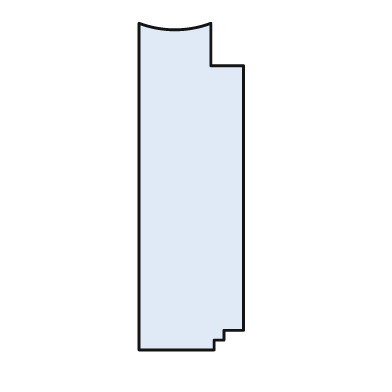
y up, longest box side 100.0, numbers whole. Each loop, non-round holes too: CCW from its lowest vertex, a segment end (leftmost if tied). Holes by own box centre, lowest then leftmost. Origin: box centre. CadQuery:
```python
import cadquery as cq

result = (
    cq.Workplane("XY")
    .moveTo(-16.0, -50.0)
    .lineTo(7.0, -50.0)
    .lineTo(7.0, -47.0)
    .lineTo(10.0, -47.0)
    .lineTo(10.0, -44.0)
    .lineTo(16.0, -44.0)
    .lineTo(16.0, 37.0)
    .lineTo(6.0, 37.0)
    .lineTo(6.0, 50.0)
    .threePointArc((-5.0, 48.0), (-16.0, 50.0))
    .close()
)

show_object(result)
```